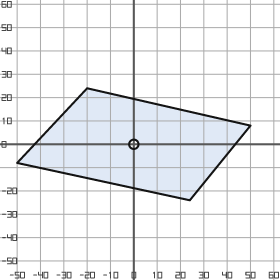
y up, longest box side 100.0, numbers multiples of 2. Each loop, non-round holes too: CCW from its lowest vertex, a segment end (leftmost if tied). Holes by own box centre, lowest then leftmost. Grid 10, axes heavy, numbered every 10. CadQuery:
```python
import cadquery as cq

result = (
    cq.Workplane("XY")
    .moveTo(24.0, -24.0)
    .lineTo(50.0, 8.0)
    .lineTo(-20.0, 24.0)
    .lineTo(-50.0, -8.0)
    .close()
    .moveTo(0.0, 0.0)
    .circle(2.0)
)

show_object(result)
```